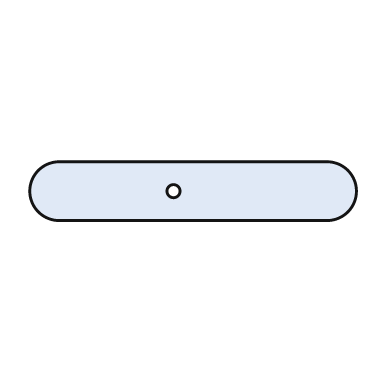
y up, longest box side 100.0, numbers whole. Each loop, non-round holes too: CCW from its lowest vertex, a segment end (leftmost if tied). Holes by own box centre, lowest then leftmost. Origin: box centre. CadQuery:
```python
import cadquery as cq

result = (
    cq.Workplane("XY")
    .moveTo(-41.0, -9.0)
    .lineTo(41.0, -9.0)
    .threePointArc((50.0, 0.0), (41.0, 9.0))
    .lineTo(-41.0, 9.0)
    .threePointArc((-50.0, 0.0), (-41.0, -9.0))
    .close()
    .moveTo(-6.0, 0.0)
    .circle(2.0)
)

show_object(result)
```